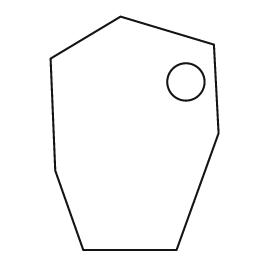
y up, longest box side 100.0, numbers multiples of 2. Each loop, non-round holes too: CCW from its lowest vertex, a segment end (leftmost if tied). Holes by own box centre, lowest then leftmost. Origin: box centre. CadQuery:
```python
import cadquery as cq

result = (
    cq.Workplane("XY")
    .moveTo(-22.0, -50.0)
    .lineTo(18.0, -50.0)
    .lineTo(36.0, 0.0)
    .lineTo(34.0, 38.0)
    .lineTo(-6.0, 50.0)
    .lineTo(-36.0, 32.0)
    .lineTo(-34.0, -16.0)
    .close()
    .moveTo(22.0, 22.0)
    .circle(8.0)
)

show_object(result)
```